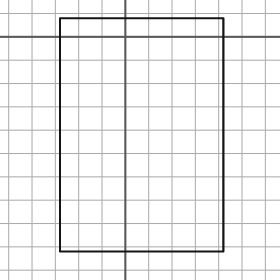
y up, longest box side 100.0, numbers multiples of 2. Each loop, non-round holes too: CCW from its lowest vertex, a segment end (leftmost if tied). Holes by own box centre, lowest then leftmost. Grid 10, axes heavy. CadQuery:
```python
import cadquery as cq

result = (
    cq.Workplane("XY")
    .moveTo(-28.0, -92.0)
    .lineTo(42.0, -92.0)
    .lineTo(42.0, 8.0)
    .lineTo(-28.0, 8.0)
    .close()
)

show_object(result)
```